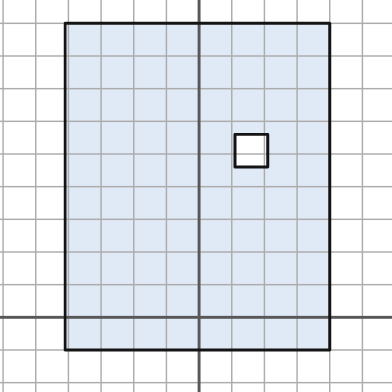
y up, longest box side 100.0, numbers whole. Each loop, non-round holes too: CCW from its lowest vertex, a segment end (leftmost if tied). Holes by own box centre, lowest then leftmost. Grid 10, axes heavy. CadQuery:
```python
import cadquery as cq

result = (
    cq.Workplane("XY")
    .moveTo(-41.0, -10.0)
    .lineTo(40.0, -10.0)
    .lineTo(40.0, 90.0)
    .lineTo(-41.0, 90.0)
    .close()
    .moveTo(11.0, 46.0)
    .lineTo(21.0, 46.0)
    .lineTo(21.0, 56.0)
    .lineTo(11.0, 56.0)
    .close()
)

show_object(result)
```